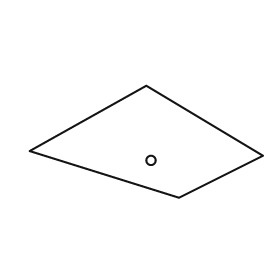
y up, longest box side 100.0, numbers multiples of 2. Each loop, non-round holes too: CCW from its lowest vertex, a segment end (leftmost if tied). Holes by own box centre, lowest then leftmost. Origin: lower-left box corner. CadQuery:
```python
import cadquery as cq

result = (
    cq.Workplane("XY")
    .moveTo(64.0, 0.0)
    .lineTo(100.0, 18.0)
    .lineTo(50.0, 48.0)
    .lineTo(0.0, 20.0)
    .close()
    .moveTo(52.0, 16.0)
    .circle(2.0)
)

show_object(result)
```